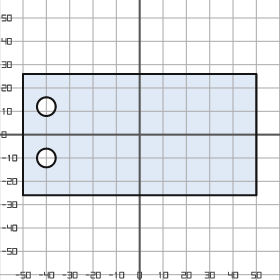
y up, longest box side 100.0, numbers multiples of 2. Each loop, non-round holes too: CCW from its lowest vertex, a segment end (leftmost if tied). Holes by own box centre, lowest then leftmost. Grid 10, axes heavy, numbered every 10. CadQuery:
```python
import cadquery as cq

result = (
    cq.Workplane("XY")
    .moveTo(-50.0, -26.0)
    .lineTo(50.0, -26.0)
    .lineTo(50.0, 26.0)
    .lineTo(-50.0, 26.0)
    .close()
    .moveTo(-40.0, -10.0)
    .circle(4.0)
    .moveTo(-40.0, 12.0)
    .circle(4.0)
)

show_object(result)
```